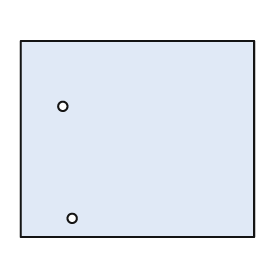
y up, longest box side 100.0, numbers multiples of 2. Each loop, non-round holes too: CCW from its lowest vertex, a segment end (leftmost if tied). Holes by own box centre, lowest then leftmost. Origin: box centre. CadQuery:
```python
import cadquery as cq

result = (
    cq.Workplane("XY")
    .moveTo(-50.0, -42.0)
    .lineTo(50.0, -42.0)
    .lineTo(50.0, 42.0)
    .lineTo(-50.0, 42.0)
    .close()
    .moveTo(-28.0, -34.0)
    .circle(2.0)
    .moveTo(-32.0, 14.0)
    .circle(2.0)
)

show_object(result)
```